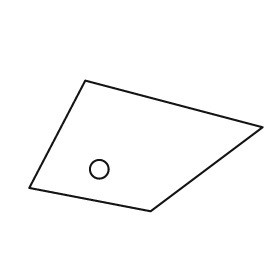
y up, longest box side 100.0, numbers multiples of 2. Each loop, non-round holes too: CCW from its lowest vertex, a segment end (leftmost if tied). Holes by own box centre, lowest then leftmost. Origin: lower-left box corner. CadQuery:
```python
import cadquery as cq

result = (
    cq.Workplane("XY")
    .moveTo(52.0, 0.0)
    .lineTo(100.0, 36.0)
    .lineTo(24.0, 56.0)
    .lineTo(0.0, 10.0)
    .close()
    .moveTo(30.0, 18.0)
    .circle(4.0)
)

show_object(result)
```